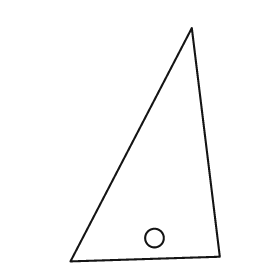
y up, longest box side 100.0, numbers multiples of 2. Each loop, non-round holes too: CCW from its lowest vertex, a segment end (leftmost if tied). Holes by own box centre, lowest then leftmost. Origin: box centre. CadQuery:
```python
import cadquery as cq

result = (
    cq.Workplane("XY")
    .moveTo(-32.0, -50.0)
    .lineTo(32.0, -48.0)
    .lineTo(20.0, 50.0)
    .close()
    .moveTo(4.0, -40.0)
    .circle(4.0)
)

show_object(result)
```